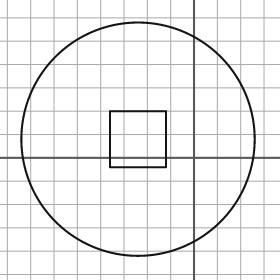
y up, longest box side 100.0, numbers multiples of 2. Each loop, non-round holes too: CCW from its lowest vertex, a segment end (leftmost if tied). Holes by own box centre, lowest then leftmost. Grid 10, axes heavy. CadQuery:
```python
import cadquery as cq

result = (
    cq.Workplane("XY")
    .moveTo(-24.0, 8.0)
    .circle(50.0)
    .moveTo(-36.0, -4.0)
    .lineTo(-12.0, -4.0)
    .lineTo(-12.0, 20.0)
    .lineTo(-36.0, 20.0)
    .close()
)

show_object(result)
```